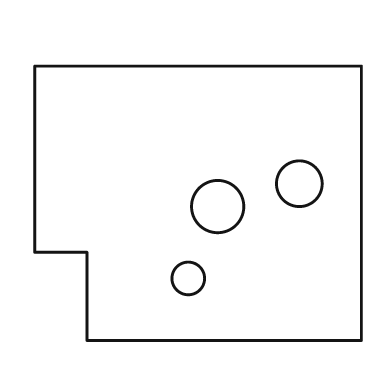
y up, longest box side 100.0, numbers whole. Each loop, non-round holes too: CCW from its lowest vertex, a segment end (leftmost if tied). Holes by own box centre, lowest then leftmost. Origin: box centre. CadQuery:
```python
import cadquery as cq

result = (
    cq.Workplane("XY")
    .moveTo(-34.0, -42.0)
    .lineTo(50.0, -42.0)
    .lineTo(50.0, 42.0)
    .lineTo(-50.0, 42.0)
    .lineTo(-50.0, -15.0)
    .lineTo(-34.0, -15.0)
    .close()
    .moveTo(-3.0, -23.0)
    .circle(5.0)
    .moveTo(6.0, -1.0)
    .circle(8.0)
    .moveTo(31.0, 6.0)
    .circle(7.0)
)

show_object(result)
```